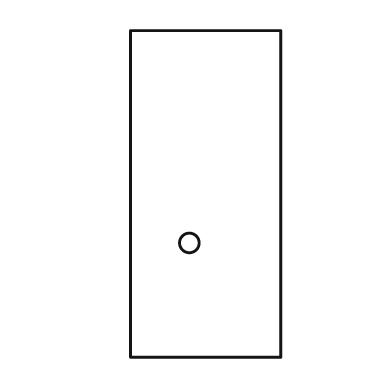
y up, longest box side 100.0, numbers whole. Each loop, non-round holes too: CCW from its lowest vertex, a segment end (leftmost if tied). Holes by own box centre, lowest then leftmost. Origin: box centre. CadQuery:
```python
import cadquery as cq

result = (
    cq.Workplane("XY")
    .moveTo(-23.0, -50.0)
    .lineTo(23.0, -50.0)
    .lineTo(23.0, 50.0)
    .lineTo(-23.0, 50.0)
    .close()
    .moveTo(-5.0, -15.0)
    .circle(3.0)
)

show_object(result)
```